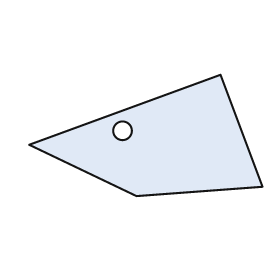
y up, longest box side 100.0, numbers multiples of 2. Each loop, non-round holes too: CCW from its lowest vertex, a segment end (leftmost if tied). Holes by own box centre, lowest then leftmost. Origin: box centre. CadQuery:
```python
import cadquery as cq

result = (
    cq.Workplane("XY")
    .moveTo(-4.0, -26.0)
    .lineTo(50.0, -22.0)
    .lineTo(32.0, 26.0)
    .lineTo(-50.0, -4.0)
    .close()
    .moveTo(-10.0, 2.0)
    .circle(4.0)
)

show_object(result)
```